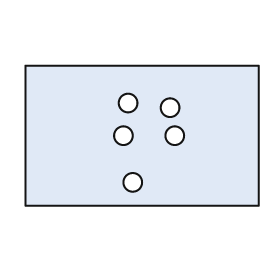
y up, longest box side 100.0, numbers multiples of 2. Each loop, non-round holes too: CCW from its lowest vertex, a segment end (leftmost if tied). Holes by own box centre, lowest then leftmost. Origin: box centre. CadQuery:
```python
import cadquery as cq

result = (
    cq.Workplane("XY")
    .moveTo(-50.0, -30.0)
    .lineTo(50.0, -30.0)
    .lineTo(50.0, 30.0)
    .lineTo(-50.0, 30.0)
    .close()
    .moveTo(-4.0, -20.0)
    .circle(4.0)
    .moveTo(-8.0, 0.0)
    .circle(4.0)
    .moveTo(14.0, 0.0)
    .circle(4.0)
    .moveTo(12.0, 12.0)
    .circle(4.0)
    .moveTo(-6.0, 14.0)
    .circle(4.0)
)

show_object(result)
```